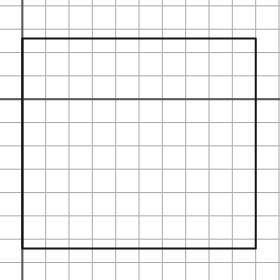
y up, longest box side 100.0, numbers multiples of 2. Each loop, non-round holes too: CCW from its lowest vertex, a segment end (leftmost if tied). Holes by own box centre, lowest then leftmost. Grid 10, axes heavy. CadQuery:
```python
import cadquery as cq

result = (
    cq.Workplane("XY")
    .moveTo(0.0, -64.0)
    .lineTo(100.0, -64.0)
    .lineTo(100.0, 26.0)
    .lineTo(0.0, 26.0)
    .close()
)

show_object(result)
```